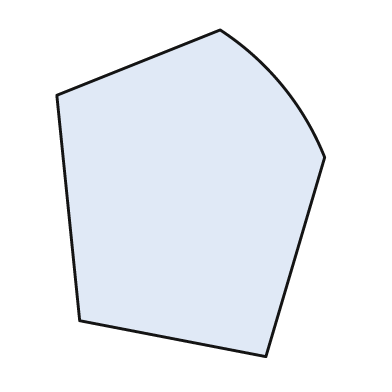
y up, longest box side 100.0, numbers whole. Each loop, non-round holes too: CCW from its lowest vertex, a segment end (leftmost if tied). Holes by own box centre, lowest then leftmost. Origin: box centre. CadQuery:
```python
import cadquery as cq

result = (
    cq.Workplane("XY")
    .moveTo(23.0, -50.0)
    .lineTo(41.0, 11.0)
    .threePointArc((28.0, 33.0), (9.0, 50.0))
    .lineTo(-41.0, 30.0)
    .lineTo(-34.0, -39.0)
    .close()
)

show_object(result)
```